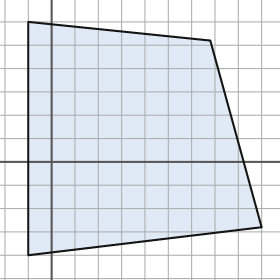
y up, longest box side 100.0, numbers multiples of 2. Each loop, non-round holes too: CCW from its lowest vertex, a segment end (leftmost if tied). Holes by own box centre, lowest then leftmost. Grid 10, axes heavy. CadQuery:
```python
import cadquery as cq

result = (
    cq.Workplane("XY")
    .moveTo(-10.0, -40.0)
    .lineTo(90.0, -28.0)
    .lineTo(68.0, 52.0)
    .lineTo(-10.0, 60.0)
    .close()
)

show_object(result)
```